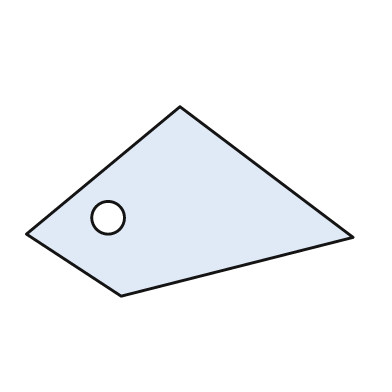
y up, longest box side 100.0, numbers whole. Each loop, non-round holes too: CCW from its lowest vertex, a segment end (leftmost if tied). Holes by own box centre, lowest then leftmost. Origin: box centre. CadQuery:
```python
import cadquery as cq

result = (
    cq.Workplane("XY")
    .moveTo(-21.0, -29.0)
    .lineTo(50.0, -11.0)
    .lineTo(-3.0, 29.0)
    .lineTo(-50.0, -10.0)
    .close()
    .moveTo(-25.0, -5.0)
    .circle(5.0)
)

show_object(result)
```